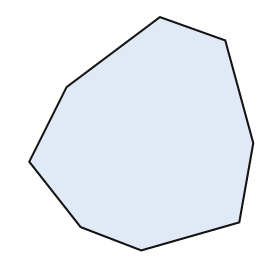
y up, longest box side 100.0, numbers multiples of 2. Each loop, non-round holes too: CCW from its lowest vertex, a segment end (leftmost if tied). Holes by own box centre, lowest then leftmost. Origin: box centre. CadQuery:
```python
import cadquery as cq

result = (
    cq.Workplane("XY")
    .moveTo(0.0, -50.0)
    .lineTo(42.0, -38.0)
    .lineTo(48.0, -4.0)
    .lineTo(36.0, 40.0)
    .lineTo(8.0, 50.0)
    .lineTo(-32.0, 20.0)
    .lineTo(-48.0, -12.0)
    .lineTo(-26.0, -40.0)
    .close()
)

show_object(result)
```